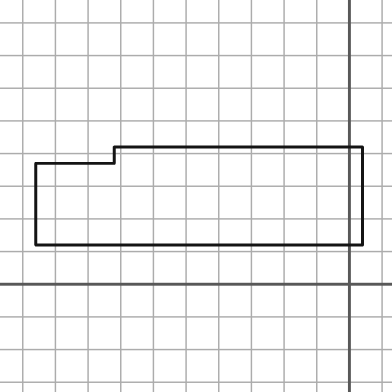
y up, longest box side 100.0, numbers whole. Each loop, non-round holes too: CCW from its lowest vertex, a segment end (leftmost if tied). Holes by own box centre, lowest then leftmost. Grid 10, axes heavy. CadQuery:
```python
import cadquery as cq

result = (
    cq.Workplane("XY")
    .moveTo(-96.0, 12.0)
    .lineTo(4.0, 12.0)
    .lineTo(4.0, 42.0)
    .lineTo(-72.0, 42.0)
    .lineTo(-72.0, 37.0)
    .lineTo(-96.0, 37.0)
    .close()
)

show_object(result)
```